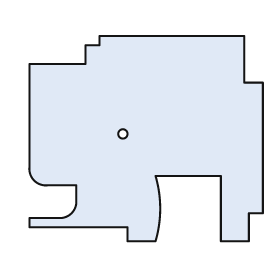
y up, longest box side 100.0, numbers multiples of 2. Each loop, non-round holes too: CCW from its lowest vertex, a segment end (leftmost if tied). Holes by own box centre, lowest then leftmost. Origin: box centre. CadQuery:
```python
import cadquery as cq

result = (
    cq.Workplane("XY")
    .moveTo(-8.0, -44.0)
    .lineTo(4.0, -44.0)
    .threePointArc((6.0, -30.0), (4.0, -16.0))
    .lineTo(32.0, -16.0)
    .lineTo(32.0, -44.0)
    .lineTo(44.0, -44.0)
    .lineTo(44.0, -32.0)
    .lineTo(50.0, -32.0)
    .lineTo(50.0, 24.0)
    .lineTo(42.0, 24.0)
    .lineTo(42.0, 44.0)
    .lineTo(-20.0, 44.0)
    .lineTo(-20.0, 40.0)
    .lineTo(-26.0, 40.0)
    .lineTo(-26.0, 32.0)
    .lineTo(-50.0, 32.0)
    .lineTo(-50.0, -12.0)
    .threePointArc((-48.0, -18.0), (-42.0, -20.0))
    .lineTo(-30.0, -20.0)
    .lineTo(-30.0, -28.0)
    .threePointArc((-32.0, -32.0), (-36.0, -34.0))
    .lineTo(-50.0, -34.0)
    .lineTo(-50.0, -38.0)
    .lineTo(-8.0, -38.0)
    .close()
    .moveTo(-10.0, 2.0)
    .circle(2.0)
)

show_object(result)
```